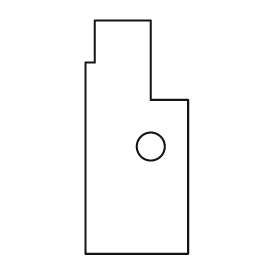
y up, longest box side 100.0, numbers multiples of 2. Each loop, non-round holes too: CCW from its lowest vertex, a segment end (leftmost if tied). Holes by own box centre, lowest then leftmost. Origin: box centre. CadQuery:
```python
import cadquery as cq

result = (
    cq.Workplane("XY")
    .moveTo(-22.0, -50.0)
    .lineTo(22.0, -50.0)
    .lineTo(22.0, 16.0)
    .lineTo(6.0, 16.0)
    .lineTo(6.0, 50.0)
    .lineTo(-18.0, 50.0)
    .lineTo(-18.0, 32.0)
    .lineTo(-22.0, 32.0)
    .close()
    .moveTo(6.0, -4.0)
    .circle(6.0)
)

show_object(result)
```